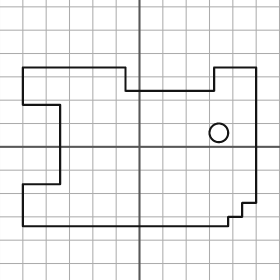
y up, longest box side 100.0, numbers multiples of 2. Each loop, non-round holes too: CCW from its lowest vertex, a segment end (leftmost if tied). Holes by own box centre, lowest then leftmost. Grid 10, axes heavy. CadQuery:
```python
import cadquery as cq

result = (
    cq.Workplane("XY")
    .moveTo(-50.0, -34.0)
    .lineTo(38.0, -34.0)
    .lineTo(38.0, -30.0)
    .lineTo(44.0, -30.0)
    .lineTo(44.0, -24.0)
    .lineTo(50.0, -24.0)
    .lineTo(50.0, 34.0)
    .lineTo(32.0, 34.0)
    .lineTo(32.0, 24.0)
    .lineTo(-6.0, 24.0)
    .lineTo(-6.0, 34.0)
    .lineTo(-50.0, 34.0)
    .lineTo(-50.0, 18.0)
    .lineTo(-34.0, 18.0)
    .lineTo(-34.0, -16.0)
    .lineTo(-50.0, -16.0)
    .close()
    .moveTo(34.0, 6.0)
    .circle(4.0)
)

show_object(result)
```